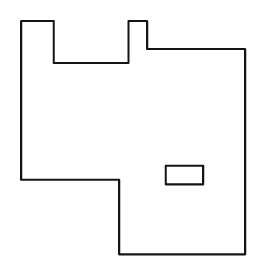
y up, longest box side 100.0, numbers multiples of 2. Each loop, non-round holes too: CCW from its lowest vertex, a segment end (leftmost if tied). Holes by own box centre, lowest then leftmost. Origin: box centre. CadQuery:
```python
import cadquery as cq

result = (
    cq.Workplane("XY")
    .moveTo(-6.0, -50.0)
    .lineTo(48.0, -50.0)
    .lineTo(48.0, 38.0)
    .lineTo(6.0, 38.0)
    .lineTo(6.0, 50.0)
    .lineTo(-2.0, 50.0)
    .lineTo(-2.0, 32.0)
    .lineTo(-34.0, 32.0)
    .lineTo(-34.0, 50.0)
    .lineTo(-48.0, 50.0)
    .lineTo(-48.0, -18.0)
    .lineTo(-6.0, -18.0)
    .close()
    .moveTo(14.0, -20.0)
    .lineTo(30.0, -20.0)
    .lineTo(30.0, -12.0)
    .lineTo(14.0, -12.0)
    .close()
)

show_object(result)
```